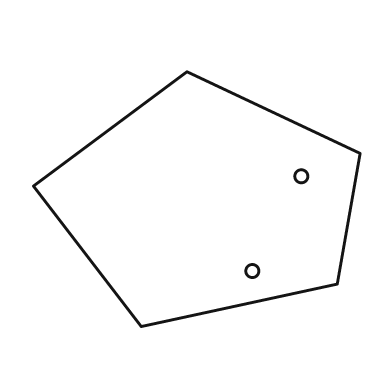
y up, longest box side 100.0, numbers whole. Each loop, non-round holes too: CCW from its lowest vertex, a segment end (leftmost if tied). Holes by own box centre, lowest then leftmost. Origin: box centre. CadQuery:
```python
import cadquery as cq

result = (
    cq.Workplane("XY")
    .moveTo(-17.0, -39.0)
    .lineTo(43.0, -26.0)
    .lineTo(50.0, 14.0)
    .lineTo(-3.0, 39.0)
    .lineTo(-50.0, 4.0)
    .close()
    .moveTo(17.0, -22.0)
    .circle(2.0)
    .moveTo(32.0, 7.0)
    .circle(2.0)
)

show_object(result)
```